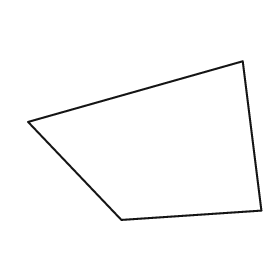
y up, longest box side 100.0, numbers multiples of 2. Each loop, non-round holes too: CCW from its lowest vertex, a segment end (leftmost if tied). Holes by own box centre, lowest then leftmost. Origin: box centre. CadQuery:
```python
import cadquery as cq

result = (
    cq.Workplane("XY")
    .moveTo(-10.0, -34.0)
    .lineTo(50.0, -30.0)
    .lineTo(42.0, 34.0)
    .lineTo(-50.0, 8.0)
    .close()
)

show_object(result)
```